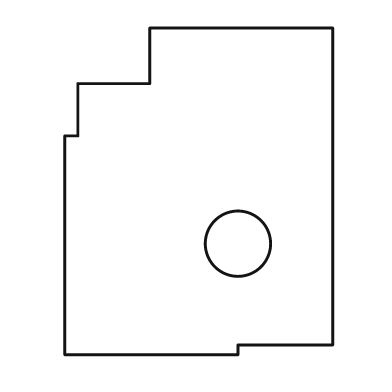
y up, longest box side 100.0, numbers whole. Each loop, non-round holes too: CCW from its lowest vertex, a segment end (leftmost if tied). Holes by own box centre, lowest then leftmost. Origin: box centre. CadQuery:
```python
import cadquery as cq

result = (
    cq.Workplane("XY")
    .moveTo(-41.0, -50.0)
    .lineTo(12.0, -50.0)
    .lineTo(12.0, -47.0)
    .lineTo(41.0, -47.0)
    .lineTo(41.0, 50.0)
    .lineTo(-15.0, 50.0)
    .lineTo(-15.0, 33.0)
    .lineTo(-37.0, 33.0)
    .lineTo(-37.0, 17.0)
    .lineTo(-41.0, 17.0)
    .close()
    .moveTo(12.0, -16.0)
    .circle(10.0)
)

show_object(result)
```